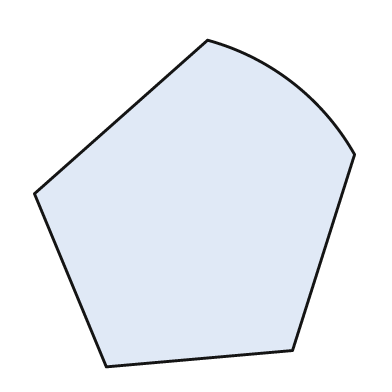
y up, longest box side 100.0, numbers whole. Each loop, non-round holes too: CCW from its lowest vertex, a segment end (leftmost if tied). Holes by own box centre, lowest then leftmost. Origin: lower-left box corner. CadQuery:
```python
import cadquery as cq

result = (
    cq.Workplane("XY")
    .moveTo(22.0, 0.0)
    .lineTo(79.0, 5.0)
    .lineTo(98.0, 65.0)
    .threePointArc((79.0, 87.0), (53.0, 100.0))
    .lineTo(0.0, 53.0)
    .close()
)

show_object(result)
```